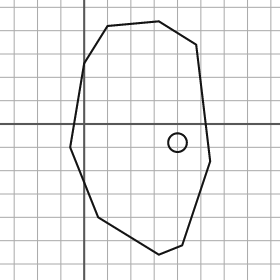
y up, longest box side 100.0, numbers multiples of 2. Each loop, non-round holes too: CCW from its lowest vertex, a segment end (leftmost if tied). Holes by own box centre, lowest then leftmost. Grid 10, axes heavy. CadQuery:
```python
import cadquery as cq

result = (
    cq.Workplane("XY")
    .moveTo(32.0, -56.0)
    .lineTo(42.0, -52.0)
    .lineTo(54.0, -16.0)
    .lineTo(48.0, 34.0)
    .lineTo(32.0, 44.0)
    .lineTo(10.0, 42.0)
    .lineTo(0.0, 26.0)
    .lineTo(-6.0, -10.0)
    .lineTo(6.0, -40.0)
    .close()
    .moveTo(40.0, -8.0)
    .circle(4.0)
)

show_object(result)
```